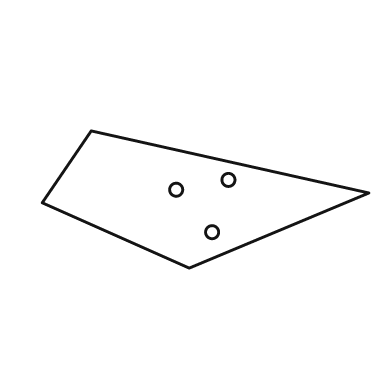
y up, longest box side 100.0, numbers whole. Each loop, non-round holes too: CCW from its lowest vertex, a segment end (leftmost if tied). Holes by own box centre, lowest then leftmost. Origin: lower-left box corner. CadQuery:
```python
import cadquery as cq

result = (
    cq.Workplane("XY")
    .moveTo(45.0, 0.0)
    .lineTo(100.0, 23.0)
    .lineTo(15.0, 42.0)
    .lineTo(0.0, 20.0)
    .close()
    .moveTo(52.0, 11.0)
    .circle(2.0)
    .moveTo(41.0, 24.0)
    .circle(2.0)
    .moveTo(57.0, 27.0)
    .circle(2.0)
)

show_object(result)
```